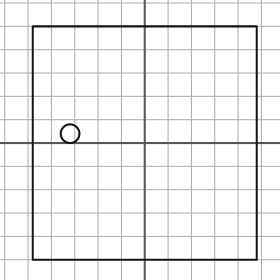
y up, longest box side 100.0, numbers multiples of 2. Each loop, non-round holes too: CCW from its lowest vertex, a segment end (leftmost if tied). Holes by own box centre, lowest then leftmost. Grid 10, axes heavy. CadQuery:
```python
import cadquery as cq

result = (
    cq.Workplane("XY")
    .moveTo(-48.0, -50.0)
    .lineTo(48.0, -50.0)
    .lineTo(48.0, 50.0)
    .lineTo(-48.0, 50.0)
    .close()
    .moveTo(-32.0, 4.0)
    .circle(4.0)
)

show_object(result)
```